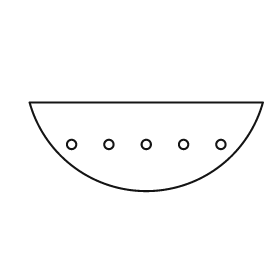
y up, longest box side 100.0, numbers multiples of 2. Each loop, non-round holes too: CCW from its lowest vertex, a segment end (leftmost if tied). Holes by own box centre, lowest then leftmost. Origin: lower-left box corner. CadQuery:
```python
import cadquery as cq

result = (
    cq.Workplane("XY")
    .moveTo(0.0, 38.0)
    .threePointArc((50.0, 0.0), (100.0, 38.0))
    .close()
    .moveTo(18.0, 20.0)
    .circle(2.0)
    .moveTo(34.0, 20.0)
    .circle(2.0)
    .moveTo(50.0, 20.0)
    .circle(2.0)
    .moveTo(66.0, 20.0)
    .circle(2.0)
    .moveTo(82.0, 20.0)
    .circle(2.0)
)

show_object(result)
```